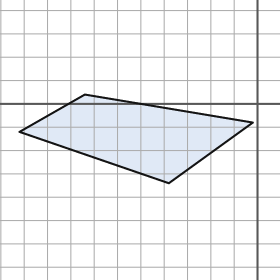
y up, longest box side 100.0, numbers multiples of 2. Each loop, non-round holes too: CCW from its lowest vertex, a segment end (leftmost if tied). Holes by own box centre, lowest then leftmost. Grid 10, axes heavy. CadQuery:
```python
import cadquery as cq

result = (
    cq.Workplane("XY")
    .moveTo(-38.0, -34.0)
    .lineTo(-2.0, -8.0)
    .lineTo(-74.0, 4.0)
    .lineTo(-102.0, -12.0)
    .close()
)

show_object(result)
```